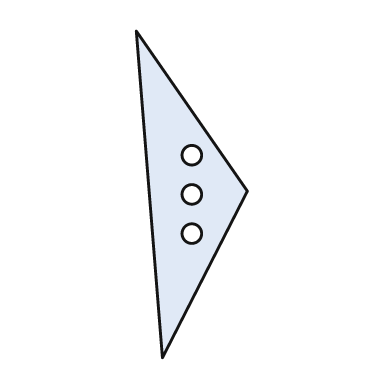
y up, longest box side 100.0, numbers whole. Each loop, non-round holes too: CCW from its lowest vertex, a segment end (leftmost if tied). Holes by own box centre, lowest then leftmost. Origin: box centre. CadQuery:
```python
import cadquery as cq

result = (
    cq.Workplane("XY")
    .moveTo(-9.0, -50.0)
    .lineTo(17.0, 1.0)
    .lineTo(-17.0, 50.0)
    .close()
    .moveTo(0.0, -12.0)
    .circle(3.0)
    .moveTo(0.0, 0.0)
    .circle(3.0)
    .moveTo(0.0, 12.0)
    .circle(3.0)
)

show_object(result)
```